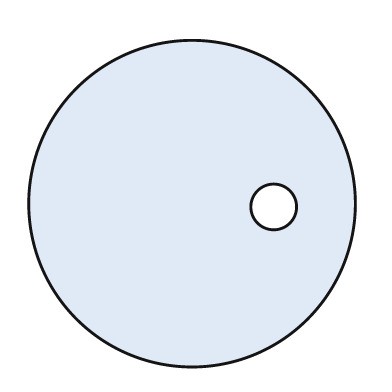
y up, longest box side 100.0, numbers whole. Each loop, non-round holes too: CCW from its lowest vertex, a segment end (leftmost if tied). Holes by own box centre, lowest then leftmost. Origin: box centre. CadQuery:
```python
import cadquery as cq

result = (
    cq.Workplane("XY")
    .moveTo(0.0, 0.0)
    .circle(50.0)
    .moveTo(25.0, -1.0)
    .circle(7.0)
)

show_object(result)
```